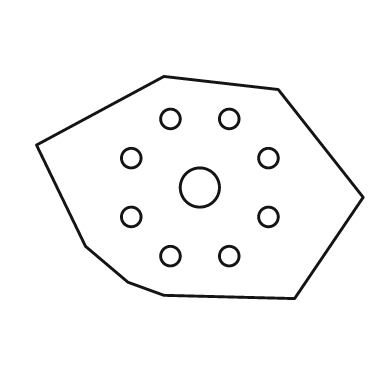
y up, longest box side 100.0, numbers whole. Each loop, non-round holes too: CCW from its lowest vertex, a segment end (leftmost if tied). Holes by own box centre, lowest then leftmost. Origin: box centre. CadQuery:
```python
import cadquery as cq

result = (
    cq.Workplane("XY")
    .moveTo(29.0, -34.0)
    .lineTo(50.0, -3.0)
    .lineTo(24.0, 30.0)
    .lineTo(-11.0, 34.0)
    .lineTo(-50.0, 13.0)
    .lineTo(-35.0, -18.0)
    .lineTo(-22.0, -29.0)
    .lineTo(-11.0, -33.0)
    .close()
    .moveTo(-9.0, -21.0)
    .circle(3.0)
    .moveTo(9.0, -21.0)
    .circle(3.0)
    .moveTo(-21.0, -9.0)
    .circle(3.0)
    .moveTo(21.0, -9.0)
    .circle(3.0)
    .moveTo(0.0, 0.0)
    .circle(6.0)
    .moveTo(-21.0, 9.0)
    .circle(3.0)
    .moveTo(21.0, 9.0)
    .circle(3.0)
    .moveTo(-9.0, 21.0)
    .circle(3.0)
    .moveTo(9.0, 21.0)
    .circle(3.0)
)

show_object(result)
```